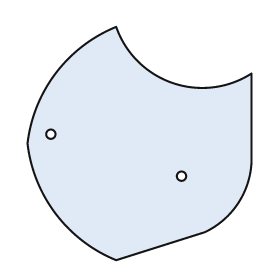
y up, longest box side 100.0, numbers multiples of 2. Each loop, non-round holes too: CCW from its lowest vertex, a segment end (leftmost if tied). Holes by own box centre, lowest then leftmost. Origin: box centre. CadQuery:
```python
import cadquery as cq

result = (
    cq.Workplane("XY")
    .moveTo(-10.0, -50.0)
    .lineTo(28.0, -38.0)
    .threePointArc((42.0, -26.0), (48.0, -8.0))
    .lineTo(48.0, 30.0)
    .threePointArc((14.0, 26.0), (-10.0, 50.0))
    .threePointArc((-36.0, 30.0), (-48.0, 0.0))
    .threePointArc((-36.0, -30.0), (-10.0, -50.0))
    .close()
    .moveTo(18.0, -14.0)
    .circle(2.0)
    .moveTo(-38.0, 4.0)
    .circle(2.0)
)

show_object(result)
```